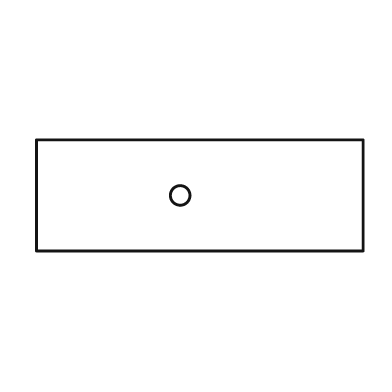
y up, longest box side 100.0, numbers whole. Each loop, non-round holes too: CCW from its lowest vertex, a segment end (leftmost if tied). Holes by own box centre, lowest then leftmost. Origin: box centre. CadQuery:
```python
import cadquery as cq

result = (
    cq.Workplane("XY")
    .moveTo(-50.0, -17.0)
    .lineTo(50.0, -17.0)
    .lineTo(50.0, 17.0)
    .lineTo(-50.0, 17.0)
    .close()
    .moveTo(-6.0, 0.0)
    .circle(3.0)
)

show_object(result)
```